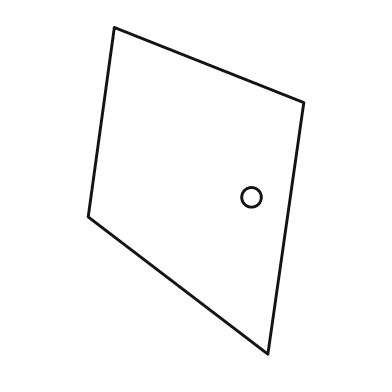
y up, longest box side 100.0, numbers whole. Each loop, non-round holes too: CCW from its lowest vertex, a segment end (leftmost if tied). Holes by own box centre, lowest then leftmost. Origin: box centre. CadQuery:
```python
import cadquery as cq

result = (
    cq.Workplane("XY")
    .moveTo(22.0, -50.0)
    .lineTo(33.0, 27.0)
    .lineTo(-25.0, 50.0)
    .lineTo(-33.0, -8.0)
    .close()
    .moveTo(17.0, -2.0)
    .circle(3.0)
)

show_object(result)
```